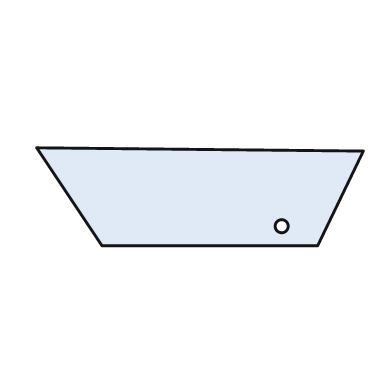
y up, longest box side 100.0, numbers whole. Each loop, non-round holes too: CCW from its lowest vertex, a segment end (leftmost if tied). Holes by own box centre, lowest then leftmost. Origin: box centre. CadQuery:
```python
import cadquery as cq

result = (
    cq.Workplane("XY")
    .moveTo(-30.0, -15.0)
    .lineTo(36.0, -15.0)
    .lineTo(50.0, 14.0)
    .lineTo(-50.0, 15.0)
    .close()
    .moveTo(25.0, -9.0)
    .circle(2.0)
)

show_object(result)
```